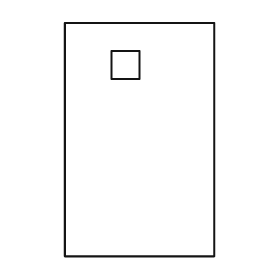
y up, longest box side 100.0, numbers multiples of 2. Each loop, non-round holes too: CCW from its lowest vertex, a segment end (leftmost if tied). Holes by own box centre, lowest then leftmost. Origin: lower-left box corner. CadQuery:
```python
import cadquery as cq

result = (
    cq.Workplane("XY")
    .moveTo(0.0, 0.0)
    .lineTo(64.0, 0.0)
    .lineTo(64.0, 100.0)
    .lineTo(0.0, 100.0)
    .close()
    .moveTo(20.0, 76.0)
    .lineTo(32.0, 76.0)
    .lineTo(32.0, 88.0)
    .lineTo(20.0, 88.0)
    .close()
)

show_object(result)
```